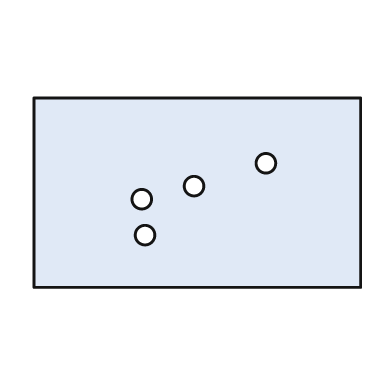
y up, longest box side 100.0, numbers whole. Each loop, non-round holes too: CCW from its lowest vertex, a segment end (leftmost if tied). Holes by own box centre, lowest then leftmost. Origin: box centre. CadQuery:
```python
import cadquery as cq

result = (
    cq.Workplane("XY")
    .moveTo(-50.0, -29.0)
    .lineTo(50.0, -29.0)
    .lineTo(50.0, 29.0)
    .lineTo(-50.0, 29.0)
    .close()
    .moveTo(-16.0, -13.0)
    .circle(3.0)
    .moveTo(-17.0, -2.0)
    .circle(3.0)
    .moveTo(-1.0, 2.0)
    .circle(3.0)
    .moveTo(21.0, 9.0)
    .circle(3.0)
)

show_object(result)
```